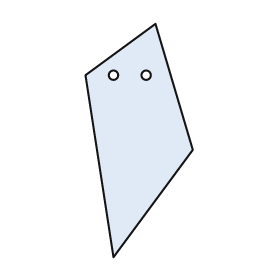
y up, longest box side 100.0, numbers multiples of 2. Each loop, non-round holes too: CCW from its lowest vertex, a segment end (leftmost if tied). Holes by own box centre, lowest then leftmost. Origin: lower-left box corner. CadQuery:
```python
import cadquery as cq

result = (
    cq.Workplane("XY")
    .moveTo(12.0, 0.0)
    .lineTo(46.0, 46.0)
    .lineTo(30.0, 100.0)
    .lineTo(0.0, 78.0)
    .close()
    .moveTo(12.0, 78.0)
    .circle(2.0)
    .moveTo(26.0, 78.0)
    .circle(2.0)
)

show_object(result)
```